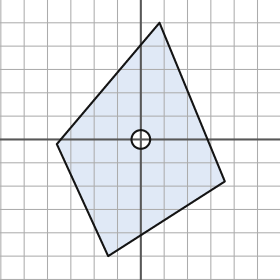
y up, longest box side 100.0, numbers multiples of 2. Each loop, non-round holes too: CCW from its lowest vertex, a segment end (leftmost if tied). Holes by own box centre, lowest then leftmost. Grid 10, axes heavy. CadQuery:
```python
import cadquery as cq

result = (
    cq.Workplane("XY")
    .moveTo(-14.0, -50.0)
    .lineTo(36.0, -18.0)
    .lineTo(8.0, 50.0)
    .lineTo(-36.0, -2.0)
    .close()
    .moveTo(0.0, 0.0)
    .circle(4.0)
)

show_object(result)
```